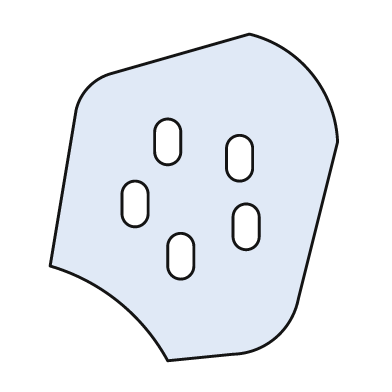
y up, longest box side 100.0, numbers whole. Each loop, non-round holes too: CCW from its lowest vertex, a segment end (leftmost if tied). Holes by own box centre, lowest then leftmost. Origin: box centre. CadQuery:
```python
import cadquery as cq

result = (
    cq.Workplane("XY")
    .moveTo(-8.0, -50.0)
    .lineTo(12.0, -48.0)
    .threePointArc((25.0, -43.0), (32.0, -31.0))
    .lineTo(44.0, 17.0)
    .threePointArc((36.0, 38.0), (17.0, 50.0))
    .lineTo(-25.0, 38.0)
    .threePointArc((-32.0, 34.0), (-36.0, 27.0))
    .lineTo(-44.0, -21.0)
    .threePointArc((-23.0, -32.0), (-8.0, -50.0))
    .close()
    .moveTo(-8.0, -21.0)
    .threePointArc((-4.0, -25.0), (0.0, -21.0))
    .lineTo(0.0, -15.0)
    .threePointArc((-4.0, -11.0), (-8.0, -15.0))
    .close()
    .moveTo(12.0, -12.0)
    .threePointArc((16.0, -16.0), (20.0, -12.0))
    .lineTo(20.0, -6.0)
    .threePointArc((16.0, -2.0), (12.0, -6.0))
    .close()
    .moveTo(-22.0, -5.0)
    .threePointArc((-18.0, -9.0), (-14.0, -5.0))
    .lineTo(-14.0, 1.0)
    .threePointArc((-18.0, 5.0), (-22.0, 1.0))
    .close()
    .moveTo(10.0, 9.0)
    .threePointArc((14.0, 5.0), (18.0, 9.0))
    .lineTo(18.0, 15.0)
    .threePointArc((14.0, 19.0), (10.0, 15.0))
    .close()
    .moveTo(-12.0, 14.0)
    .threePointArc((-8.0, 10.0), (-4.0, 14.0))
    .lineTo(-4.0, 20.0)
    .threePointArc((-8.0, 24.0), (-12.0, 20.0))
    .close()
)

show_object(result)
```